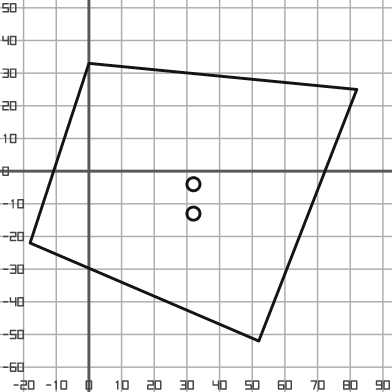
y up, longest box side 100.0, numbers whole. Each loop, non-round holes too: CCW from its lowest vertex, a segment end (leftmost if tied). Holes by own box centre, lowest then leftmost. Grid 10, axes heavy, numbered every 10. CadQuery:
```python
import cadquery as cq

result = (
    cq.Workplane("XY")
    .moveTo(52.0, -52.0)
    .lineTo(82.0, 25.0)
    .lineTo(0.0, 33.0)
    .lineTo(-18.0, -22.0)
    .close()
    .moveTo(32.0, -13.0)
    .circle(2.0)
    .moveTo(32.0, -4.0)
    .circle(2.0)
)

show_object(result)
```